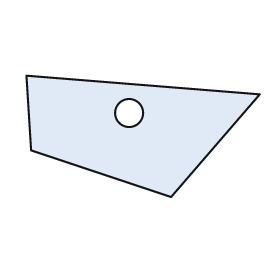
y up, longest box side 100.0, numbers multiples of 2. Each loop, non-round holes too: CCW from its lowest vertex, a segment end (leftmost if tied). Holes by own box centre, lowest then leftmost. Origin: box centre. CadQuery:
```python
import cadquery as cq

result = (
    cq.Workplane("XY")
    .moveTo(12.0, -26.0)
    .lineTo(50.0, 18.0)
    .lineTo(-50.0, 26.0)
    .lineTo(-48.0, -6.0)
    .close()
    .moveTo(-6.0, 10.0)
    .circle(6.0)
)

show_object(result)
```